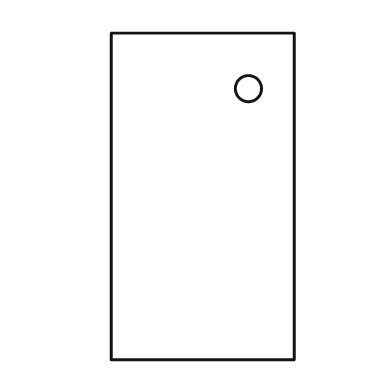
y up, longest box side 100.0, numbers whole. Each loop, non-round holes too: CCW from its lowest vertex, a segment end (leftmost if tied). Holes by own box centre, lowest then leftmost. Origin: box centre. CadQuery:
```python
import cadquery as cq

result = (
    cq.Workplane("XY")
    .moveTo(-28.0, -50.0)
    .lineTo(28.0, -50.0)
    .lineTo(28.0, 50.0)
    .lineTo(-28.0, 50.0)
    .close()
    .moveTo(14.0, 33.0)
    .circle(4.0)
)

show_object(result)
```